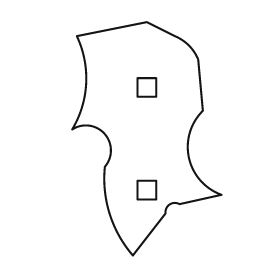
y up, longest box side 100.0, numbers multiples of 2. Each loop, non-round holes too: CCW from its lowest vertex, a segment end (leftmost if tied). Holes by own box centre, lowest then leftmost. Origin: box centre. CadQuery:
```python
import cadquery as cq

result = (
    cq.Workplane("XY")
    .moveTo(-6.0, -50.0)
    .lineTo(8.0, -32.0)
    .threePointArc((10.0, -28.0), (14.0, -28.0))
    .lineTo(32.0, -24.0)
    .threePointArc((18.0, -8.0), (24.0, 12.0))
    .lineTo(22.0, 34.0)
    .threePointArc((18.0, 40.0), (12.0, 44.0))
    .lineTo(0.0, 50.0)
    .lineTo(-30.0, 44.0)
    .threePointArc((-26.0, 24.0), (-32.0, 4.0))
    .threePointArc((-18.0, 2.0), (-18.0, -12.0))
    .threePointArc((-16.0, -32.0), (-6.0, -50.0))
    .close()
    .moveTo(-4.0, -26.0)
    .lineTo(4.0, -26.0)
    .lineTo(4.0, -18.0)
    .lineTo(-4.0, -18.0)
    .close()
    .moveTo(-4.0, 18.0)
    .lineTo(4.0, 18.0)
    .lineTo(4.0, 26.0)
    .lineTo(-4.0, 26.0)
    .close()
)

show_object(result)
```